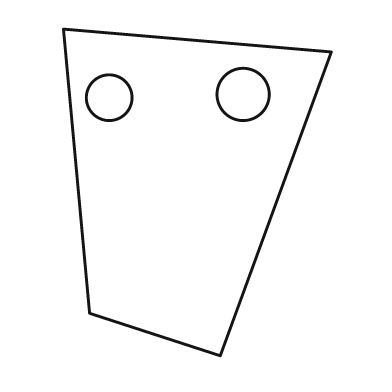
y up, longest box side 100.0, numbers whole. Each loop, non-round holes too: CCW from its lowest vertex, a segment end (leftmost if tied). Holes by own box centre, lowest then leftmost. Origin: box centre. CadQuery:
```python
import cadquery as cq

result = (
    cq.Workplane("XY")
    .moveTo(7.0, -50.0)
    .lineTo(41.0, 43.0)
    .lineTo(-41.0, 50.0)
    .lineTo(-33.0, -37.0)
    .close()
    .moveTo(-27.0, 29.0)
    .circle(7.0)
    .moveTo(14.0, 30.0)
    .circle(8.0)
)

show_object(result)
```